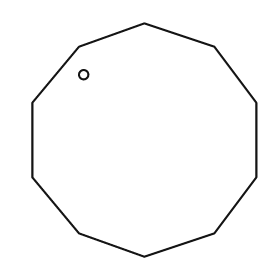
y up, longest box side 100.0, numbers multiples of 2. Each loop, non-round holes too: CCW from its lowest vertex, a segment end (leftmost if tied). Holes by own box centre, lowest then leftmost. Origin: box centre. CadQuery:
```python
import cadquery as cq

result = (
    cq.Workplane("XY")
    .moveTo(0.0, -50.0)
    .lineTo(30.0, -40.0)
    .lineTo(48.0, -16.0)
    .lineTo(48.0, 16.0)
    .lineTo(30.0, 40.0)
    .lineTo(0.0, 50.0)
    .lineTo(-28.0, 40.0)
    .lineTo(-48.0, 16.0)
    .lineTo(-48.0, -16.0)
    .lineTo(-28.0, -40.0)
    .close()
    .moveTo(-26.0, 28.0)
    .circle(2.0)
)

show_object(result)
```